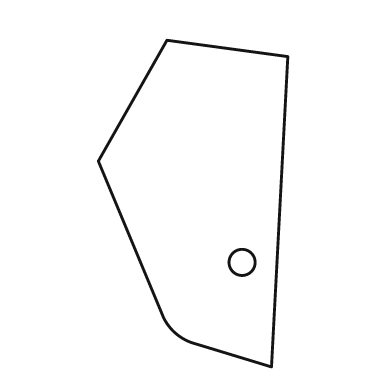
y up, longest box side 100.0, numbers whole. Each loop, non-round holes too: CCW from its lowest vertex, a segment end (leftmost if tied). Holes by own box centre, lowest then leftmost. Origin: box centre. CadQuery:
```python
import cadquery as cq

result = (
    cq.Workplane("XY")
    .moveTo(24.0, -50.0)
    .lineTo(29.0, 45.0)
    .lineTo(-8.0, 50.0)
    .lineTo(-29.0, 13.0)
    .lineTo(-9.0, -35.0)
    .threePointArc((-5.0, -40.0), (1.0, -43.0))
    .close()
    .moveTo(15.0, -18.0)
    .circle(4.0)
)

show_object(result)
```